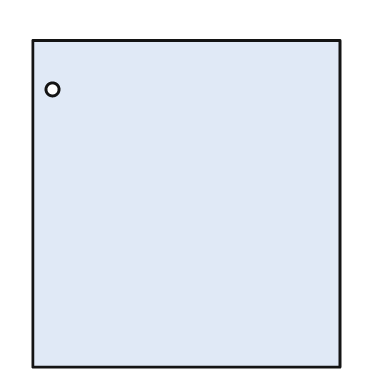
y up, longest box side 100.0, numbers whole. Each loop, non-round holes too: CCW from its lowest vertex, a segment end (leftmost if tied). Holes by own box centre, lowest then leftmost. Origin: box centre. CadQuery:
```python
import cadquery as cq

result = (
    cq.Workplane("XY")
    .moveTo(-47.0, -50.0)
    .lineTo(47.0, -50.0)
    .lineTo(47.0, 50.0)
    .lineTo(-47.0, 50.0)
    .close()
    .moveTo(-41.0, 35.0)
    .circle(2.0)
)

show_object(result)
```